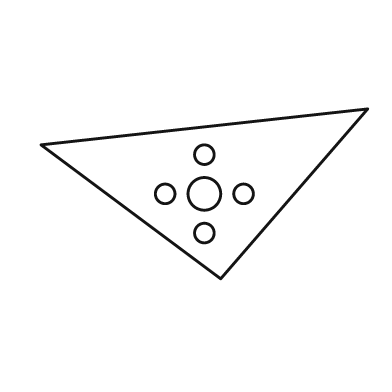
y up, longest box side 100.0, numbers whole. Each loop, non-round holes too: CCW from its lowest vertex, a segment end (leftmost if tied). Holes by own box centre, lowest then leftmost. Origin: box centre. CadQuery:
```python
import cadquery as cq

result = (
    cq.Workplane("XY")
    .moveTo(5.0, -26.0)
    .lineTo(50.0, 26.0)
    .lineTo(-50.0, 15.0)
    .close()
    .moveTo(0.0, -12.0)
    .circle(3.0)
    .moveTo(-12.0, 0.0)
    .circle(3.0)
    .moveTo(0.0, 0.0)
    .circle(5.0)
    .moveTo(12.0, 0.0)
    .circle(3.0)
    .moveTo(0.0, 12.0)
    .circle(3.0)
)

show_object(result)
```